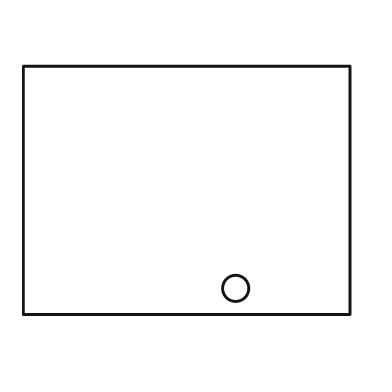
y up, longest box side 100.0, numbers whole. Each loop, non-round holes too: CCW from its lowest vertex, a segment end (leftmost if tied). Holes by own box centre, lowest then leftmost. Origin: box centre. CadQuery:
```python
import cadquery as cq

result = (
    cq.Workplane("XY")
    .moveTo(-50.0, -38.0)
    .lineTo(50.0, -38.0)
    .lineTo(50.0, 38.0)
    .lineTo(-50.0, 38.0)
    .close()
    .moveTo(15.0, -30.0)
    .circle(4.0)
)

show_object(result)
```